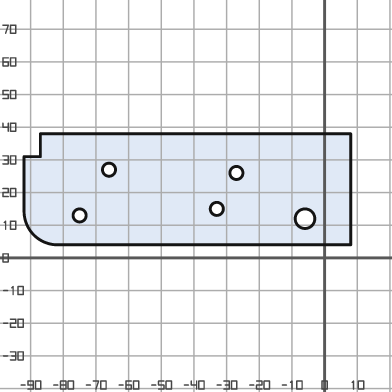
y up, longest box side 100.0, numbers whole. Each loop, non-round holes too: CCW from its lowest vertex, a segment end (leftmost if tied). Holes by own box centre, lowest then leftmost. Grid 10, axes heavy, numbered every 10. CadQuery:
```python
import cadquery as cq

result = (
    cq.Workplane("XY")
    .moveTo(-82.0, 4.0)
    .lineTo(8.0, 4.0)
    .lineTo(8.0, 38.0)
    .lineTo(-87.0, 38.0)
    .lineTo(-87.0, 31.0)
    .lineTo(-92.0, 31.0)
    .lineTo(-92.0, 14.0)
    .threePointArc((-89.0, 7.0), (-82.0, 4.0))
    .close()
    .moveTo(-6.0, 12.0)
    .circle(3.0)
    .moveTo(-75.0, 13.0)
    .circle(2.0)
    .moveTo(-33.0, 15.0)
    .circle(2.0)
    .moveTo(-27.0, 26.0)
    .circle(2.0)
    .moveTo(-66.0, 27.0)
    .circle(2.0)
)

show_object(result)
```